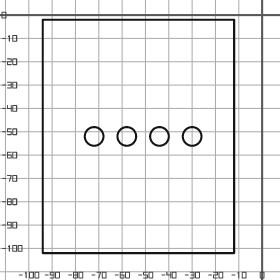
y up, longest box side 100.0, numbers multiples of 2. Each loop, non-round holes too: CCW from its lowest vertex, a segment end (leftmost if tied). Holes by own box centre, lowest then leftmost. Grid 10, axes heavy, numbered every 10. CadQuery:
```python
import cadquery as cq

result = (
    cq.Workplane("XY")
    .moveTo(-94.0, -102.0)
    .lineTo(-12.0, -102.0)
    .lineTo(-12.0, -2.0)
    .lineTo(-94.0, -2.0)
    .close()
    .moveTo(-72.0, -52.0)
    .circle(4.0)
    .moveTo(-58.0, -52.0)
    .circle(4.0)
    .moveTo(-44.0, -52.0)
    .circle(4.0)
    .moveTo(-30.0, -52.0)
    .circle(4.0)
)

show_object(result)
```